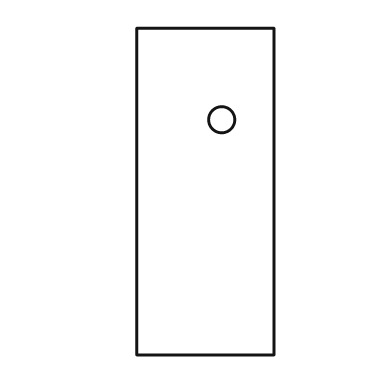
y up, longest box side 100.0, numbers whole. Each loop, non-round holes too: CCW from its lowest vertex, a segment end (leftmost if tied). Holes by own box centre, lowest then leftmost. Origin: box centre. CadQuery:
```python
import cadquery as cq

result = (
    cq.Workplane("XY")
    .moveTo(-21.0, -50.0)
    .lineTo(21.0, -50.0)
    .lineTo(21.0, 50.0)
    .lineTo(-21.0, 50.0)
    .close()
    .moveTo(5.0, 22.0)
    .circle(4.0)
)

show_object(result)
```